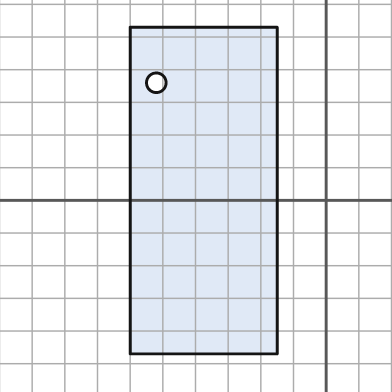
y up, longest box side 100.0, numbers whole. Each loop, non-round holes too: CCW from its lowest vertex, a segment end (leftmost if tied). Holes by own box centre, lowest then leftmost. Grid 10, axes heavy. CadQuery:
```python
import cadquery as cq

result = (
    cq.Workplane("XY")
    .moveTo(-60.0, -47.0)
    .lineTo(-15.0, -47.0)
    .lineTo(-15.0, 53.0)
    .lineTo(-60.0, 53.0)
    .close()
    .moveTo(-52.0, 36.0)
    .circle(3.0)
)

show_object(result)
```